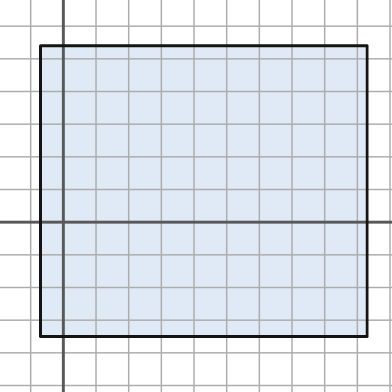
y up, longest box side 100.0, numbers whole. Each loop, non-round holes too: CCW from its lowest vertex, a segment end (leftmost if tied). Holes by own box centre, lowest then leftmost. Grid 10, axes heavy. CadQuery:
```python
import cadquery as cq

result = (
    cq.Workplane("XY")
    .moveTo(-7.0, -35.0)
    .lineTo(93.0, -35.0)
    .lineTo(93.0, 54.0)
    .lineTo(-7.0, 54.0)
    .close()
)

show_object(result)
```